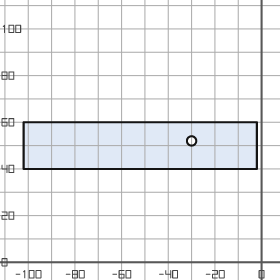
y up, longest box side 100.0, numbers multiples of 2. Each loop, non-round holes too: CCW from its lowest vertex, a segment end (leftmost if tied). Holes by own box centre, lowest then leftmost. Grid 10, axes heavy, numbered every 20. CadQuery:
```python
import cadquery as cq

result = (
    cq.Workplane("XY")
    .moveTo(-102.0, 40.0)
    .lineTo(-2.0, 40.0)
    .lineTo(-2.0, 60.0)
    .lineTo(-102.0, 60.0)
    .close()
    .moveTo(-30.0, 52.0)
    .circle(2.0)
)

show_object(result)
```